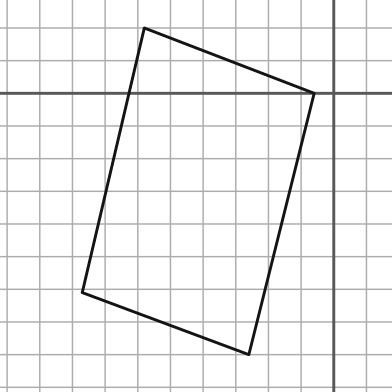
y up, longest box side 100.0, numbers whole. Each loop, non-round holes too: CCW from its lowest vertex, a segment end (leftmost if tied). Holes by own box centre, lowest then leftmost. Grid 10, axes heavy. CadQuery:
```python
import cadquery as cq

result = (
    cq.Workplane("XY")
    .moveTo(-26.0, -80.0)
    .lineTo(-6.0, 0.0)
    .lineTo(-58.0, 20.0)
    .lineTo(-77.0, -61.0)
    .close()
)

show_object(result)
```